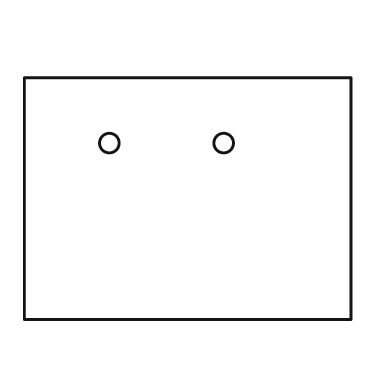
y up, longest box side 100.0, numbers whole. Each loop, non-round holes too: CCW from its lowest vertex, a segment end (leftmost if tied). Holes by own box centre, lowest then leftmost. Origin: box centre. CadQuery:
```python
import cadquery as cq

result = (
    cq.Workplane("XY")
    .moveTo(-50.0, -37.0)
    .lineTo(50.0, -37.0)
    .lineTo(50.0, 37.0)
    .lineTo(-50.0, 37.0)
    .close()
    .moveTo(-24.0, 17.0)
    .circle(3.0)
    .moveTo(11.0, 17.0)
    .circle(3.0)
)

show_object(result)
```